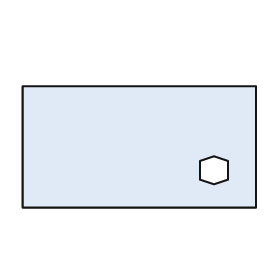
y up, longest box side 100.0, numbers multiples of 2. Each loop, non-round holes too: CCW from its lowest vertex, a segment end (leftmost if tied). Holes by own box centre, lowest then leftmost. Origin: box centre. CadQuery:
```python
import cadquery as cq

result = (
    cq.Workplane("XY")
    .moveTo(-50.0, -26.0)
    .lineTo(50.0, -26.0)
    .lineTo(50.0, 26.0)
    .lineTo(-50.0, 26.0)
    .close()
    .moveTo(32.0, -16.0)
    .lineTo(38.0, -14.0)
    .lineTo(38.0, -6.0)
    .lineTo(32.0, -4.0)
    .lineTo(26.0, -6.0)
    .lineTo(26.0, -14.0)
    .close()
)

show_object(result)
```